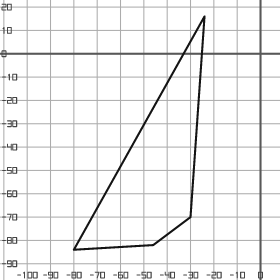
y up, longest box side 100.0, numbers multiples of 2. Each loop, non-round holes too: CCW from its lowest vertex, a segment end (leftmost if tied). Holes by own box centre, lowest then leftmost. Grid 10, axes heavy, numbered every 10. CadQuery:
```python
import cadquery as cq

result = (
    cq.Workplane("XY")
    .moveTo(-80.0, -84.0)
    .lineTo(-46.0, -82.0)
    .lineTo(-30.0, -70.0)
    .lineTo(-24.0, 16.0)
    .close()
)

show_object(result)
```